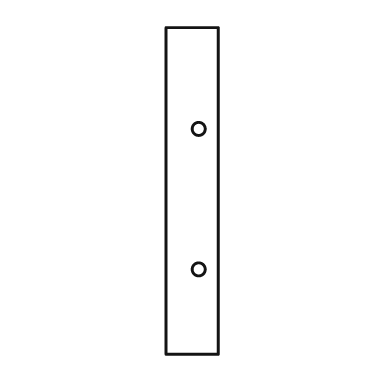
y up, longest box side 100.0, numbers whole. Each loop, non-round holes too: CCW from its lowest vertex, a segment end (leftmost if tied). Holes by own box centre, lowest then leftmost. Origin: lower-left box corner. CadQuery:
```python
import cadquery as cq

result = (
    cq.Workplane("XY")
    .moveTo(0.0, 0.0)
    .lineTo(16.0, 0.0)
    .lineTo(16.0, 100.0)
    .lineTo(0.0, 100.0)
    .close()
    .moveTo(10.0, 26.0)
    .circle(2.0)
    .moveTo(10.0, 69.0)
    .circle(2.0)
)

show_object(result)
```